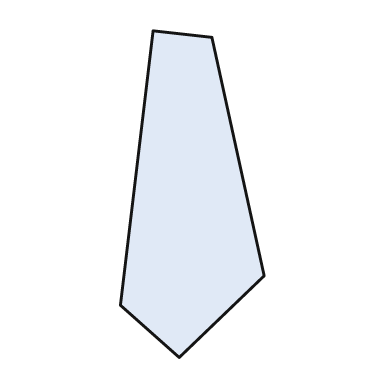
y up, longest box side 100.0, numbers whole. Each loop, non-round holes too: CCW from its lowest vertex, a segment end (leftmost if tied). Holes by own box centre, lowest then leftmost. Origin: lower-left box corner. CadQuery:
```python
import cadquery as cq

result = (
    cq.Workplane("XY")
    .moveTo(18.0, 0.0)
    .lineTo(44.0, 25.0)
    .lineTo(28.0, 98.0)
    .lineTo(10.0, 100.0)
    .lineTo(0.0, 16.0)
    .close()
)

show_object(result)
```